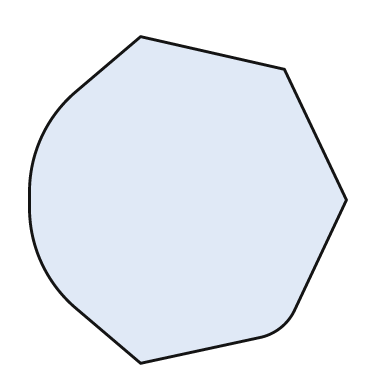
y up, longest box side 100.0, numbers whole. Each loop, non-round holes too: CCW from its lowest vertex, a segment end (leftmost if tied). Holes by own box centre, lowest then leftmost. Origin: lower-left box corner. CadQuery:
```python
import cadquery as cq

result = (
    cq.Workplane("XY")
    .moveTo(34.0, 0.0)
    .lineTo(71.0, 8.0)
    .threePointArc((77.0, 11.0), (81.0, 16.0))
    .lineTo(97.0, 50.0)
    .lineTo(78.0, 90.0)
    .lineTo(34.0, 100.0)
    .lineTo(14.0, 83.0)
    .threePointArc((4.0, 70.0), (0.0, 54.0))
    .lineTo(0.0, 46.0)
    .threePointArc((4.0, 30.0), (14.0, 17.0))
    .close()
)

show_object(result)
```